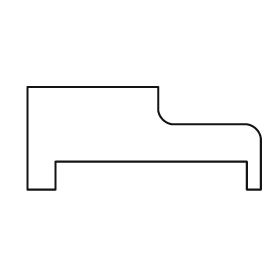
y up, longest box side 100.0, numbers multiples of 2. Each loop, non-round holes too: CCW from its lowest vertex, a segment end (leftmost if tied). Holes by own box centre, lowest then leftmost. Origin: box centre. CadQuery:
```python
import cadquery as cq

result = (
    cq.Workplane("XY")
    .moveTo(-50.0, -22.0)
    .lineTo(-38.0, -22.0)
    .lineTo(-38.0, -10.0)
    .lineTo(44.0, -10.0)
    .lineTo(44.0, -22.0)
    .lineTo(50.0, -22.0)
    .lineTo(50.0, 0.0)
    .threePointArc((48.0, 4.0), (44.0, 6.0))
    .lineTo(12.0, 6.0)
    .threePointArc((8.0, 8.0), (6.0, 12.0))
    .lineTo(6.0, 22.0)
    .lineTo(-50.0, 22.0)
    .close()
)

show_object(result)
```